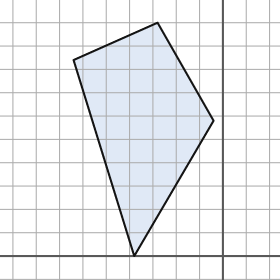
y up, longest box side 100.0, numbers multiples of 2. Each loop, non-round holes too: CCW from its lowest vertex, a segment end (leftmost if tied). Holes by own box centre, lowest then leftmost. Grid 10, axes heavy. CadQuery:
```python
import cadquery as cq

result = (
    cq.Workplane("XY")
    .moveTo(-38.0, 0.0)
    .lineTo(-4.0, 58.0)
    .lineTo(-28.0, 100.0)
    .lineTo(-64.0, 84.0)
    .close()
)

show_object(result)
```